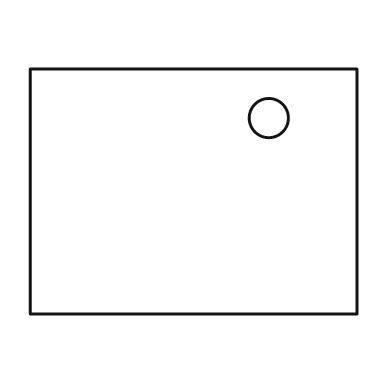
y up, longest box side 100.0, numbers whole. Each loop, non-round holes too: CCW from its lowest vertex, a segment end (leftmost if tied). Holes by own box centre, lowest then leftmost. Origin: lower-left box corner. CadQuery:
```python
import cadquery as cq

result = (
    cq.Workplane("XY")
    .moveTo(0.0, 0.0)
    .lineTo(100.0, 0.0)
    .lineTo(100.0, 75.0)
    .lineTo(0.0, 75.0)
    .close()
    .moveTo(73.0, 60.0)
    .circle(6.0)
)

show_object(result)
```